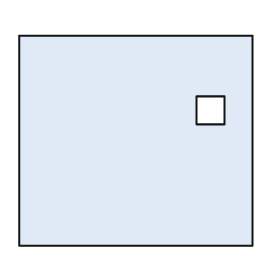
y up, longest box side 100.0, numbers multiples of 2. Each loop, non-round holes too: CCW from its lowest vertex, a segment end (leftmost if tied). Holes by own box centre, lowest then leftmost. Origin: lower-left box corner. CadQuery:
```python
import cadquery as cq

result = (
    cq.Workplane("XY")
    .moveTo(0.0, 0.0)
    .lineTo(100.0, 0.0)
    .lineTo(100.0, 90.0)
    .lineTo(0.0, 90.0)
    .close()
    .moveTo(76.0, 52.0)
    .lineTo(88.0, 52.0)
    .lineTo(88.0, 64.0)
    .lineTo(76.0, 64.0)
    .close()
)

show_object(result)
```